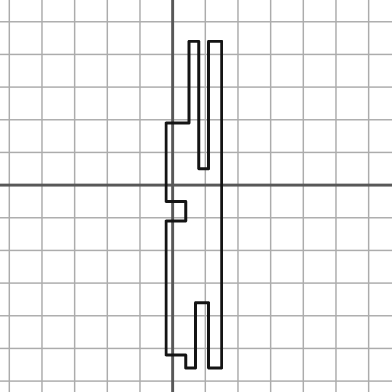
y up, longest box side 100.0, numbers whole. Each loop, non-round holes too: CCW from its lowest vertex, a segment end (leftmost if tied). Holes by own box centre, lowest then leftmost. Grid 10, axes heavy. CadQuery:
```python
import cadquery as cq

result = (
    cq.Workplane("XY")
    .moveTo(4.0, -56.0)
    .lineTo(7.0, -56.0)
    .lineTo(7.0, -36.0)
    .lineTo(11.0, -36.0)
    .lineTo(11.0, -56.0)
    .lineTo(15.0, -56.0)
    .lineTo(15.0, 44.0)
    .lineTo(11.0, 44.0)
    .lineTo(11.0, 5.0)
    .lineTo(8.0, 5.0)
    .lineTo(8.0, 44.0)
    .lineTo(5.0, 44.0)
    .lineTo(5.0, 19.0)
    .lineTo(-2.0, 19.0)
    .lineTo(-2.0, -5.0)
    .lineTo(4.0, -5.0)
    .lineTo(4.0, -11.0)
    .lineTo(-2.0, -11.0)
    .lineTo(-2.0, -52.0)
    .lineTo(4.0, -52.0)
    .close()
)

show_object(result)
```